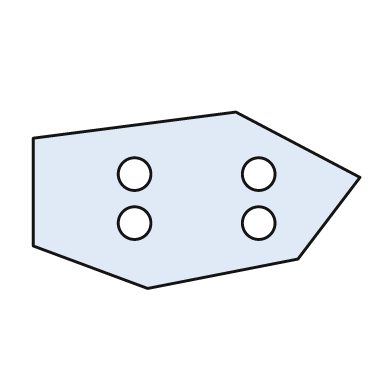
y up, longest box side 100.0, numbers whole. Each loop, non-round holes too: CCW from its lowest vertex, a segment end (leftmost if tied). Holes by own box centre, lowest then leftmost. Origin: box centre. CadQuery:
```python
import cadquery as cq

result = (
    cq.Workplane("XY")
    .moveTo(-15.0, -27.0)
    .lineTo(31.0, -18.0)
    .lineTo(50.0, 7.0)
    .lineTo(12.0, 27.0)
    .lineTo(-50.0, 19.0)
    .lineTo(-50.0, -14.0)
    .close()
    .moveTo(-19.0, -7.0)
    .circle(5.0)
    .moveTo(19.0, -7.0)
    .circle(5.0)
    .moveTo(-19.0, 8.0)
    .circle(5.0)
    .moveTo(19.0, 8.0)
    .circle(5.0)
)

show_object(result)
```